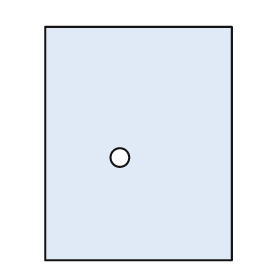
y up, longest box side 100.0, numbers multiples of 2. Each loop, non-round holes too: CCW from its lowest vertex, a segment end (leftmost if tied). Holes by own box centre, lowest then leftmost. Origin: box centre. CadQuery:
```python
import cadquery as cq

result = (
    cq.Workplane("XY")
    .moveTo(-40.0, -50.0)
    .lineTo(40.0, -50.0)
    .lineTo(40.0, 50.0)
    .lineTo(-40.0, 50.0)
    .close()
    .moveTo(-8.0, -6.0)
    .circle(4.0)
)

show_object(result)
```